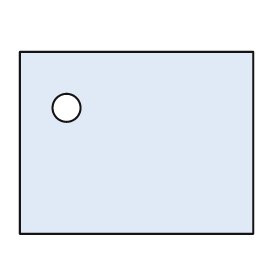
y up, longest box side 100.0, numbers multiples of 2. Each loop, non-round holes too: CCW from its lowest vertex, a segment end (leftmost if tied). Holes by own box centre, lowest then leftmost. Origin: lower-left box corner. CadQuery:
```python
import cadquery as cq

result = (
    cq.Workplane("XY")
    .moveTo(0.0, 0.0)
    .lineTo(100.0, 0.0)
    .lineTo(100.0, 78.0)
    .lineTo(0.0, 78.0)
    .close()
    .moveTo(20.0, 54.0)
    .circle(6.0)
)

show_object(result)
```